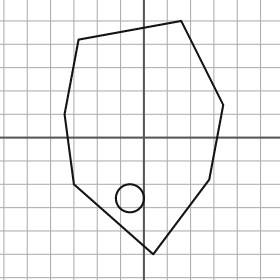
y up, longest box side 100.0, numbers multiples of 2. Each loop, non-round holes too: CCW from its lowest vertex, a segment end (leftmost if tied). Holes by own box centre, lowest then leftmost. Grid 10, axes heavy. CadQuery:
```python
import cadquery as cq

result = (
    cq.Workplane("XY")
    .moveTo(4.0, -50.0)
    .lineTo(28.0, -18.0)
    .lineTo(34.0, 14.0)
    .lineTo(16.0, 50.0)
    .lineTo(-28.0, 42.0)
    .lineTo(-34.0, 10.0)
    .lineTo(-30.0, -20.0)
    .close()
    .moveTo(-6.0, -26.0)
    .circle(6.0)
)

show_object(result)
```